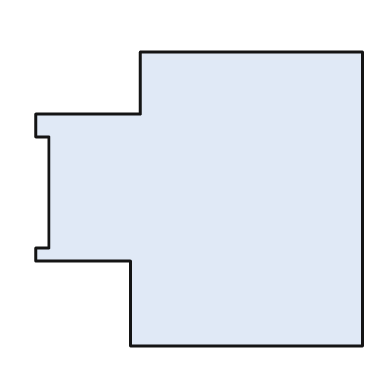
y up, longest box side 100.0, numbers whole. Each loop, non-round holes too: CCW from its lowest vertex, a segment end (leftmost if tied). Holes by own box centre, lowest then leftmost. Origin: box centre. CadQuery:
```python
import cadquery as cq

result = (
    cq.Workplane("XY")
    .moveTo(-21.0, -45.0)
    .lineTo(50.0, -45.0)
    .lineTo(50.0, 45.0)
    .lineTo(-18.0, 45.0)
    .lineTo(-18.0, 26.0)
    .lineTo(-50.0, 26.0)
    .lineTo(-50.0, 19.0)
    .lineTo(-46.0, 19.0)
    .lineTo(-46.0, -15.0)
    .lineTo(-50.0, -15.0)
    .lineTo(-50.0, -19.0)
    .lineTo(-21.0, -19.0)
    .close()
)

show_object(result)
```